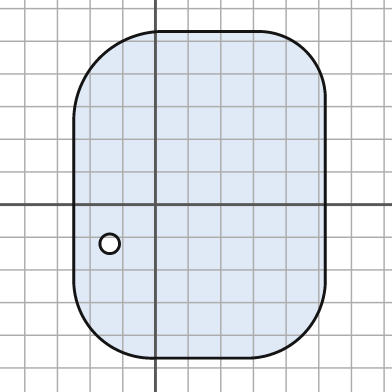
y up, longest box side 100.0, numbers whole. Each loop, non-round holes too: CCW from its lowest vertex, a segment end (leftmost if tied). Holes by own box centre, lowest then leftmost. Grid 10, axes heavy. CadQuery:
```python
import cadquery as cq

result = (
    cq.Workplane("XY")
    .moveTo(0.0, -47.0)
    .lineTo(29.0, -47.0)
    .threePointArc((45.0, -40.0), (52.0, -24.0))
    .lineTo(52.0, 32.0)
    .threePointArc((46.0, 47.0), (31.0, 53.0))
    .lineTo(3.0, 53.0)
    .threePointArc((-17.0, 45.0), (-25.0, 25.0))
    .lineTo(-25.0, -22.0)
    .threePointArc((-18.0, -40.0), (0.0, -47.0))
    .close()
    .moveTo(-14.0, -12.0)
    .circle(3.0)
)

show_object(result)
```